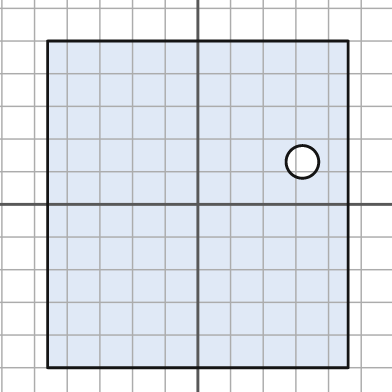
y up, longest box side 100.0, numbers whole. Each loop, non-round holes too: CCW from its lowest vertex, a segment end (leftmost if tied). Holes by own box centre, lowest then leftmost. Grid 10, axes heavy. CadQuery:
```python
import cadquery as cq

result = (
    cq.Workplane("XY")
    .moveTo(-46.0, -50.0)
    .lineTo(46.0, -50.0)
    .lineTo(46.0, 50.0)
    .lineTo(-46.0, 50.0)
    .close()
    .moveTo(32.0, 13.0)
    .circle(5.0)
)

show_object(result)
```